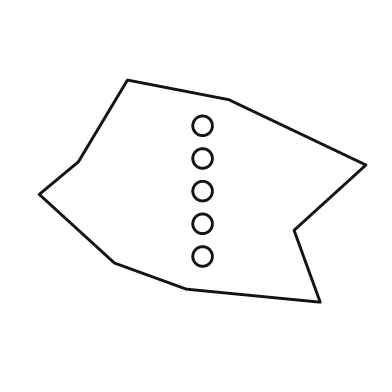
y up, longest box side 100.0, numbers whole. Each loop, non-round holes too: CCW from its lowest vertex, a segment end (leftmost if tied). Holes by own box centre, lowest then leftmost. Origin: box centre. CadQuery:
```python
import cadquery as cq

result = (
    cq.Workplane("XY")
    .moveTo(36.0, -34.0)
    .lineTo(28.0, -12.0)
    .lineTo(50.0, 8.0)
    .lineTo(8.0, 28.0)
    .lineTo(-23.0, 34.0)
    .lineTo(-38.0, 9.0)
    .lineTo(-50.0, -1.0)
    .lineTo(-27.0, -22.0)
    .lineTo(-5.0, -30.0)
    .close()
    .moveTo(0.0, -20.0)
    .circle(3.0)
    .moveTo(0.0, -10.0)
    .circle(3.0)
    .moveTo(0.0, 0.0)
    .circle(3.0)
    .moveTo(0.0, 10.0)
    .circle(3.0)
    .moveTo(0.0, 20.0)
    .circle(3.0)
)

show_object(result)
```